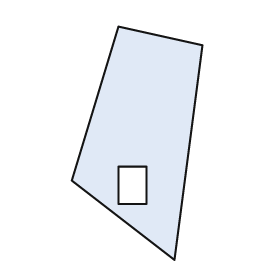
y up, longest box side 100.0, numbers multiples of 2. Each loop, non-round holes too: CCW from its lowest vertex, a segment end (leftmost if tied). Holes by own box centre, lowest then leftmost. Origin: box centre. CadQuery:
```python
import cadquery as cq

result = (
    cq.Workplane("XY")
    .moveTo(16.0, -50.0)
    .lineTo(28.0, 42.0)
    .lineTo(-8.0, 50.0)
    .lineTo(-28.0, -16.0)
    .close()
    .moveTo(-8.0, -26.0)
    .lineTo(4.0, -26.0)
    .lineTo(4.0, -10.0)
    .lineTo(-8.0, -10.0)
    .close()
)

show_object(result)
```